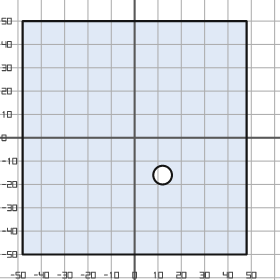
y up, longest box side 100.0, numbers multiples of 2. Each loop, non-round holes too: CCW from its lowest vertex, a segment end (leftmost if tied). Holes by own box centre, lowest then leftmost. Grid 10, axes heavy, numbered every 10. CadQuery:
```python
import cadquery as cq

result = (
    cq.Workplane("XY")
    .moveTo(-48.0, -50.0)
    .lineTo(48.0, -50.0)
    .lineTo(48.0, 50.0)
    .lineTo(-48.0, 50.0)
    .close()
    .moveTo(12.0, -16.0)
    .circle(4.0)
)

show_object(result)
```